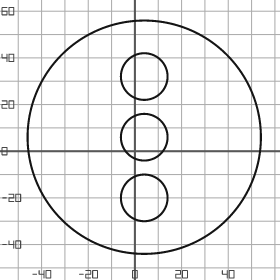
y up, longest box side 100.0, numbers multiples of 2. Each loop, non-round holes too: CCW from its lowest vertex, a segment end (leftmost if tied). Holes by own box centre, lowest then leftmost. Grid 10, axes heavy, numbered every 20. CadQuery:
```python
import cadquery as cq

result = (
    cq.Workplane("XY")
    .moveTo(4.0, 6.0)
    .circle(50.0)
    .moveTo(4.0, -20.0)
    .circle(10.0)
    .moveTo(4.0, 6.0)
    .circle(10.0)
    .moveTo(4.0, 32.0)
    .circle(10.0)
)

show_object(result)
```